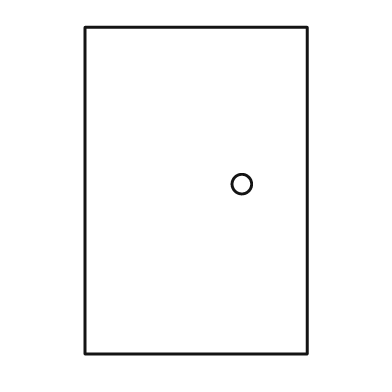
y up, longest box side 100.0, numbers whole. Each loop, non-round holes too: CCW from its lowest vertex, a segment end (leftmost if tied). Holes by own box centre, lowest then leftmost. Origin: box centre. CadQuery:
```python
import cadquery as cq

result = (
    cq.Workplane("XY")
    .moveTo(-34.0, -50.0)
    .lineTo(34.0, -50.0)
    .lineTo(34.0, 50.0)
    .lineTo(-34.0, 50.0)
    .close()
    .moveTo(14.0, 2.0)
    .circle(3.0)
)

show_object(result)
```